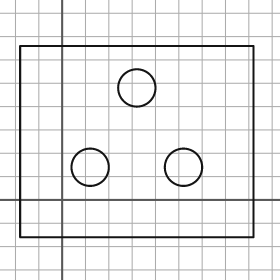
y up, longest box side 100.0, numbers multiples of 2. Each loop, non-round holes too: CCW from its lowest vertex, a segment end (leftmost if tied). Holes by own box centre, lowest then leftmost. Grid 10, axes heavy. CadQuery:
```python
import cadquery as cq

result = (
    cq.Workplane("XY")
    .moveTo(-18.0, -16.0)
    .lineTo(82.0, -16.0)
    .lineTo(82.0, 66.0)
    .lineTo(-18.0, 66.0)
    .close()
    .moveTo(12.0, 14.0)
    .circle(8.0)
    .moveTo(52.0, 14.0)
    .circle(8.0)
    .moveTo(32.0, 48.0)
    .circle(8.0)
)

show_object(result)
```